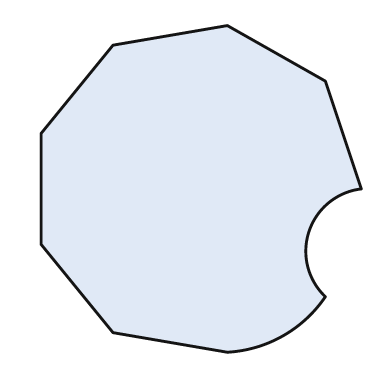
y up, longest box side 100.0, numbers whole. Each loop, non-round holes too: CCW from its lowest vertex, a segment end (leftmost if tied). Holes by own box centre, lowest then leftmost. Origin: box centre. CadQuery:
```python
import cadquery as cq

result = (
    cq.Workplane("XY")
    .moveTo(8.0, -50.0)
    .threePointArc((25.0, -45.0), (38.0, -33.0))
    .threePointArc((33.0, -13.0), (49.0, 0.0))
    .lineTo(38.0, 33.0)
    .lineTo(8.0, 50.0)
    .lineTo(-27.0, 44.0)
    .lineTo(-49.0, 17.0)
    .lineTo(-49.0, -17.0)
    .lineTo(-27.0, -44.0)
    .close()
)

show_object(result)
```